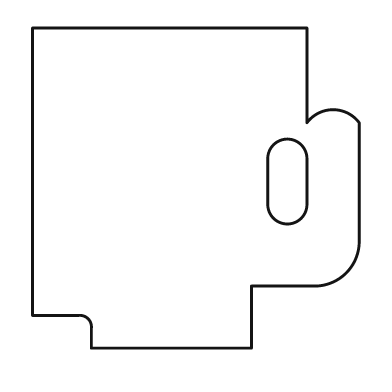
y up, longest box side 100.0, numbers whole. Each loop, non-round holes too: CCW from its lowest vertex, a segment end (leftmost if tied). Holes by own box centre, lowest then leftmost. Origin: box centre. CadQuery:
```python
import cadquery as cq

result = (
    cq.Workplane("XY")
    .moveTo(-32.0, -49.0)
    .lineTo(17.0, -49.0)
    .lineTo(17.0, -30.0)
    .lineTo(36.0, -30.0)
    .threePointArc((46.0, -26.0), (50.0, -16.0))
    .lineTo(50.0, 20.0)
    .threePointArc((42.0, 24.0), (34.0, 20.0))
    .lineTo(34.0, 49.0)
    .lineTo(-50.0, 49.0)
    .lineTo(-50.0, -39.0)
    .lineTo(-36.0, -39.0)
    .threePointArc((-33.0, -40.0), (-32.0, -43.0))
    .close()
    .moveTo(22.0, -5.0)
    .threePointArc((28.0, -11.0), (34.0, -5.0))
    .lineTo(34.0, 9.0)
    .threePointArc((28.0, 15.0), (22.0, 9.0))
    .close()
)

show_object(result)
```